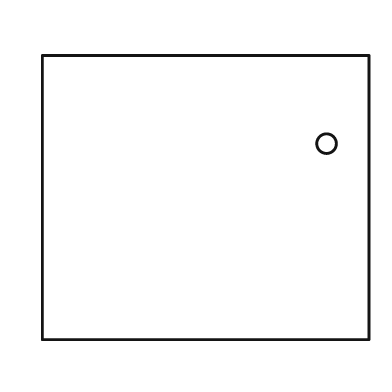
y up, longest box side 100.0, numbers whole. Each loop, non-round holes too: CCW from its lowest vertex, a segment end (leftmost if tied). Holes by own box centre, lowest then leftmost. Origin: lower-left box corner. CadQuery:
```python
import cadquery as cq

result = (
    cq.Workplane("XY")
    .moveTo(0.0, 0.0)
    .lineTo(100.0, 0.0)
    .lineTo(100.0, 87.0)
    .lineTo(0.0, 87.0)
    .close()
    .moveTo(87.0, 60.0)
    .circle(3.0)
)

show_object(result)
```